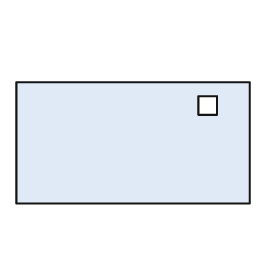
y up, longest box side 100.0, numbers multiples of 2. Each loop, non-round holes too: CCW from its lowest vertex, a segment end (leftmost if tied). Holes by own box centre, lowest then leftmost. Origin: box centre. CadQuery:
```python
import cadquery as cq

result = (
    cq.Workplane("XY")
    .moveTo(-50.0, -26.0)
    .lineTo(50.0, -26.0)
    .lineTo(50.0, 26.0)
    .lineTo(-50.0, 26.0)
    .close()
    .moveTo(28.0, 12.0)
    .lineTo(36.0, 12.0)
    .lineTo(36.0, 20.0)
    .lineTo(28.0, 20.0)
    .close()
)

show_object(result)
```